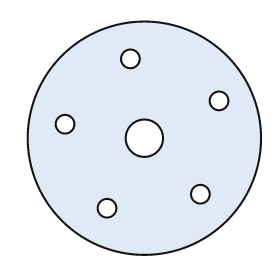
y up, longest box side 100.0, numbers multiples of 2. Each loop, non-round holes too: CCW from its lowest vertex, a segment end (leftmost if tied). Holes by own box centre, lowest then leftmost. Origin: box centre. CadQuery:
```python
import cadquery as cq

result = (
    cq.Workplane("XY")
    .moveTo(0.0, 0.0)
    .circle(50.0)
    .moveTo(-16.0, -30.0)
    .circle(4.0)
    .moveTo(24.0, -24.0)
    .circle(4.0)
    .moveTo(0.0, 0.0)
    .circle(8.0)
    .moveTo(-34.0, 6.0)
    .circle(4.0)
    .moveTo(32.0, 16.0)
    .circle(4.0)
    .moveTo(-6.0, 34.0)
    .circle(4.0)
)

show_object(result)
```